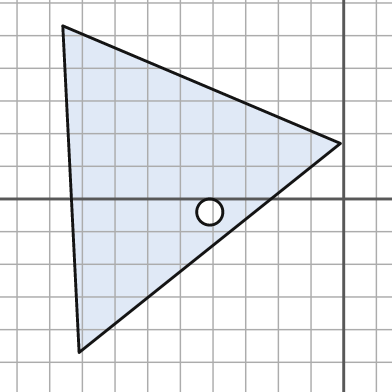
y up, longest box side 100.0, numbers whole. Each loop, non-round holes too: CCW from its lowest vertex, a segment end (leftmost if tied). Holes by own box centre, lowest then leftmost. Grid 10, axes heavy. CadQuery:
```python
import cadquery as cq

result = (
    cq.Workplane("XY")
    .moveTo(-81.0, -47.0)
    .lineTo(-1.0, 17.0)
    .lineTo(-86.0, 53.0)
    .close()
    .moveTo(-41.0, -4.0)
    .circle(4.0)
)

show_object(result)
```